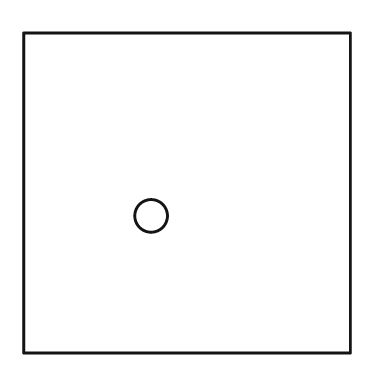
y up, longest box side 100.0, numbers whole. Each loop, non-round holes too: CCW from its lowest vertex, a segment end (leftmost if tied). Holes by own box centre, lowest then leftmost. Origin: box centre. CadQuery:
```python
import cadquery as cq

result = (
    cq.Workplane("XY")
    .moveTo(-50.0, -49.0)
    .lineTo(50.0, -49.0)
    .lineTo(50.0, 49.0)
    .lineTo(-50.0, 49.0)
    .close()
    .moveTo(-11.0, -7.0)
    .circle(5.0)
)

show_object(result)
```